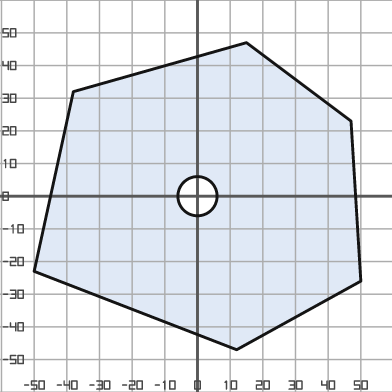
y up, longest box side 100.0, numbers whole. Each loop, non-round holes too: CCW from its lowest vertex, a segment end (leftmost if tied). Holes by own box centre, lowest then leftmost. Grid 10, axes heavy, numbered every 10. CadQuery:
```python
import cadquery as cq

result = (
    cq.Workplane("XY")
    .moveTo(12.0, -47.0)
    .lineTo(50.0, -26.0)
    .lineTo(47.0, 23.0)
    .lineTo(15.0, 47.0)
    .lineTo(-38.0, 32.0)
    .lineTo(-50.0, -23.0)
    .close()
    .moveTo(0.0, 0.0)
    .circle(6.0)
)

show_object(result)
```